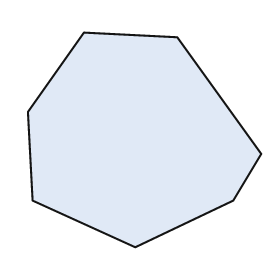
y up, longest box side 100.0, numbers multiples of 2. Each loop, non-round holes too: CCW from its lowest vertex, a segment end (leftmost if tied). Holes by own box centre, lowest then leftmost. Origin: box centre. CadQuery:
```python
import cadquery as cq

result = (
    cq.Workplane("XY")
    .moveTo(-4.0, -46.0)
    .lineTo(38.0, -26.0)
    .lineTo(50.0, -6.0)
    .lineTo(14.0, 44.0)
    .lineTo(-26.0, 46.0)
    .lineTo(-50.0, 12.0)
    .lineTo(-48.0, -26.0)
    .close()
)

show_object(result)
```